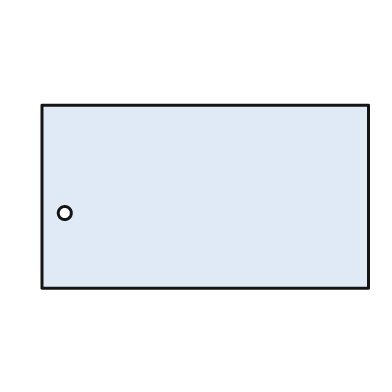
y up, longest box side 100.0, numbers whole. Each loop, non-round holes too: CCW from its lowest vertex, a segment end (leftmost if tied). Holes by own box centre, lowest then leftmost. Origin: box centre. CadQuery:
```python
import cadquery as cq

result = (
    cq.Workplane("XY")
    .moveTo(-50.0, -28.0)
    .lineTo(50.0, -28.0)
    .lineTo(50.0, 28.0)
    .lineTo(-50.0, 28.0)
    .close()
    .moveTo(-43.0, -5.0)
    .circle(2.0)
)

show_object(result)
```